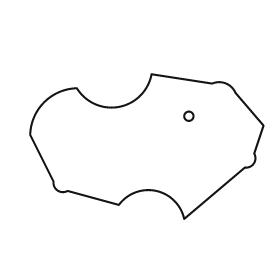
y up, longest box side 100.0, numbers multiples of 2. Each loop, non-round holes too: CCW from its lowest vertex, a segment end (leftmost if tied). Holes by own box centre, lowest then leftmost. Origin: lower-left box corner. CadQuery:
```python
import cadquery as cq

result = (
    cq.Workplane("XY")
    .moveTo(66.0, 0.0)
    .lineTo(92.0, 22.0)
    .threePointArc((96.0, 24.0), (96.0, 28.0))
    .lineTo(100.0, 40.0)
    .lineTo(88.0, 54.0)
    .threePointArc((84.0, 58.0), (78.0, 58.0))
    .lineTo(52.0, 62.0)
    .threePointArc((38.0, 48.0), (20.0, 56.0))
    .threePointArc((6.0, 50.0), (0.0, 36.0))
    .lineTo(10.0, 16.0)
    .threePointArc((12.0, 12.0), (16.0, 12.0))
    .lineTo(38.0, 6.0)
    .threePointArc((54.0, 12.0), (66.0, 0.0))
    .close()
    .moveTo(68.0, 44.0)
    .circle(2.0)
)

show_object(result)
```